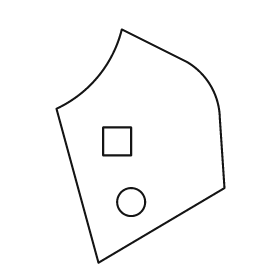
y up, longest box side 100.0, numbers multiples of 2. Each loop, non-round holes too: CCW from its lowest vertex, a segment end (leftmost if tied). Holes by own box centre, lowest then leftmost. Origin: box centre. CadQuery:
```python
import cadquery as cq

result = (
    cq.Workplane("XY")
    .moveTo(-18.0, -50.0)
    .lineTo(36.0, -18.0)
    .lineTo(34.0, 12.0)
    .threePointArc((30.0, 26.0), (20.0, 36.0))
    .lineTo(-8.0, 50.0)
    .threePointArc((-18.0, 30.0), (-36.0, 16.0))
    .close()
    .moveTo(-4.0, -24.0)
    .circle(6.0)
    .moveTo(-16.0, -4.0)
    .lineTo(-4.0, -4.0)
    .lineTo(-4.0, 8.0)
    .lineTo(-16.0, 8.0)
    .close()
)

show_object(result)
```